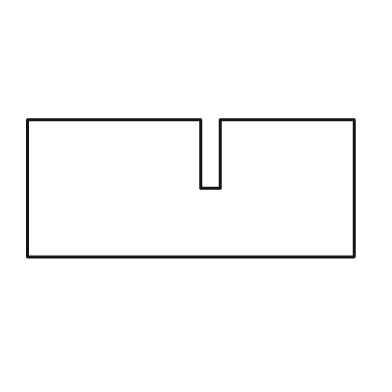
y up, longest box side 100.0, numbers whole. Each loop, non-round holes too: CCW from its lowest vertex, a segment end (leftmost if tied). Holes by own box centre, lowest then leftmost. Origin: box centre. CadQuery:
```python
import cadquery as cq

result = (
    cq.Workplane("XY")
    .moveTo(-50.0, -21.0)
    .lineTo(50.0, -21.0)
    .lineTo(50.0, 21.0)
    .lineTo(9.0, 21.0)
    .lineTo(9.0, 0.0)
    .lineTo(3.0, 0.0)
    .lineTo(3.0, 21.0)
    .lineTo(-50.0, 21.0)
    .close()
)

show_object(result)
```